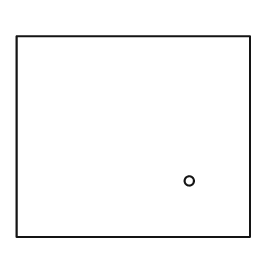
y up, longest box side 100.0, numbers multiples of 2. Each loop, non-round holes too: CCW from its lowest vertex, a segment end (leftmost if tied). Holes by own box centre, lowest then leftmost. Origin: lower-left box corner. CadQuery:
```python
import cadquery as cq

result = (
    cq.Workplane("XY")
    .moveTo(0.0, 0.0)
    .lineTo(100.0, 0.0)
    .lineTo(100.0, 86.0)
    .lineTo(0.0, 86.0)
    .close()
    .moveTo(74.0, 24.0)
    .circle(2.0)
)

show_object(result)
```